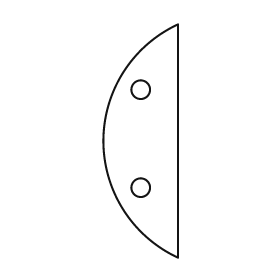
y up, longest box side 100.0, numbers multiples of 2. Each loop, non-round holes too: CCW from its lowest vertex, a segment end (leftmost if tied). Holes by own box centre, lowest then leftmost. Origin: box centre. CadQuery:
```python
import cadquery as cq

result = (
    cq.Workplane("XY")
    .moveTo(16.0, -50.0)
    .lineTo(16.0, 50.0)
    .threePointArc((-16.0, 0.0), (16.0, -50.0))
    .close()
    .moveTo(0.0, -20.0)
    .circle(4.0)
    .moveTo(0.0, 22.0)
    .circle(4.0)
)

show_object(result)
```